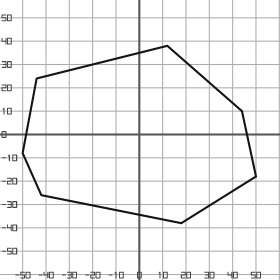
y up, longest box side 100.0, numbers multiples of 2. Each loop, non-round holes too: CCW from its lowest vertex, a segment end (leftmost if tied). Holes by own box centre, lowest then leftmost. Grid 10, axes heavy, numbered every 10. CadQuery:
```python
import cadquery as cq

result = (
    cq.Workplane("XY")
    .moveTo(18.0, -38.0)
    .lineTo(50.0, -18.0)
    .lineTo(44.0, 10.0)
    .lineTo(12.0, 38.0)
    .lineTo(-44.0, 24.0)
    .lineTo(-50.0, -8.0)
    .lineTo(-42.0, -26.0)
    .close()
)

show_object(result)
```